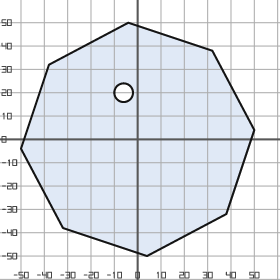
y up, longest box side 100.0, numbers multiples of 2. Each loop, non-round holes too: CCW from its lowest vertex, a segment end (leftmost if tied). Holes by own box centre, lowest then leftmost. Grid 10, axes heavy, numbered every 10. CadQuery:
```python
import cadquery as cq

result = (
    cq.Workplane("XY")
    .moveTo(4.0, -50.0)
    .lineTo(38.0, -32.0)
    .lineTo(50.0, 4.0)
    .lineTo(32.0, 38.0)
    .lineTo(-4.0, 50.0)
    .lineTo(-38.0, 32.0)
    .lineTo(-50.0, -4.0)
    .lineTo(-32.0, -38.0)
    .close()
    .moveTo(-6.0, 20.0)
    .circle(4.0)
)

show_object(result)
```